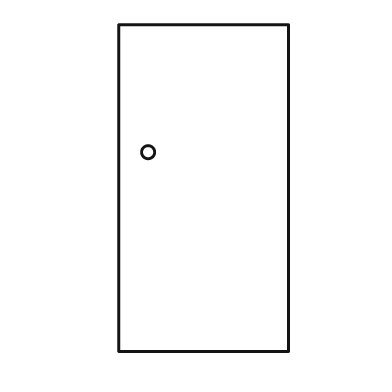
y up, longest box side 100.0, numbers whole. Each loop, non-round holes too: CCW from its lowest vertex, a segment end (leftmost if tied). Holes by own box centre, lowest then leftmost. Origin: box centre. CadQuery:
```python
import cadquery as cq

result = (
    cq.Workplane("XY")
    .moveTo(-26.0, -50.0)
    .lineTo(26.0, -50.0)
    .lineTo(26.0, 50.0)
    .lineTo(-26.0, 50.0)
    .close()
    .moveTo(-17.0, 11.0)
    .circle(2.0)
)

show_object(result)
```